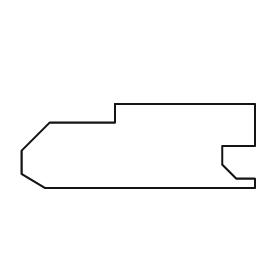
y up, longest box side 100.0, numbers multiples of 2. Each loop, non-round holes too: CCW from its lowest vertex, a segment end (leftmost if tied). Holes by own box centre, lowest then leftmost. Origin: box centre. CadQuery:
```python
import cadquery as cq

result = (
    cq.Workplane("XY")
    .moveTo(-40.0, -18.0)
    .lineTo(50.0, -18.0)
    .lineTo(50.0, -14.0)
    .lineTo(42.0, -14.0)
    .lineTo(36.0, -8.0)
    .lineTo(36.0, 0.0)
    .lineTo(50.0, 0.0)
    .lineTo(50.0, 18.0)
    .lineTo(-10.0, 18.0)
    .lineTo(-10.0, 10.0)
    .lineTo(-38.0, 10.0)
    .lineTo(-50.0, -2.0)
    .lineTo(-50.0, -12.0)
    .close()
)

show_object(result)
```